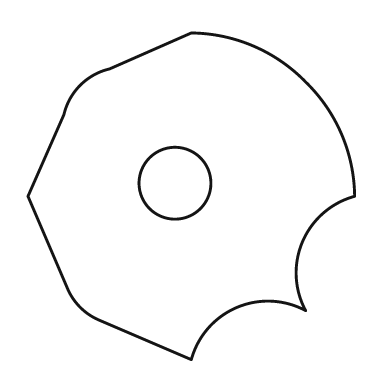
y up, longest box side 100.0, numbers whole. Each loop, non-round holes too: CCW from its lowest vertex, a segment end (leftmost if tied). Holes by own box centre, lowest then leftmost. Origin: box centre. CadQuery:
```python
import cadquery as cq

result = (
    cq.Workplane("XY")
    .moveTo(0.0, -50.0)
    .threePointArc((14.0, -34.0), (35.0, -35.0))
    .threePointArc((34.0, -14.0), (50.0, 0.0))
    .threePointArc((46.0, 19.0), (35.0, 35.0))
    .threePointArc((19.0, 46.0), (0.0, 50.0))
    .lineTo(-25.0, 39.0)
    .threePointArc((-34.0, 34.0), (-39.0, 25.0))
    .lineTo(-50.0, 0.0)
    .lineTo(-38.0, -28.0)
    .threePointArc((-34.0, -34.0), (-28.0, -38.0))
    .close()
    .moveTo(-5.0, 4.0)
    .circle(11.0)
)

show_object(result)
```